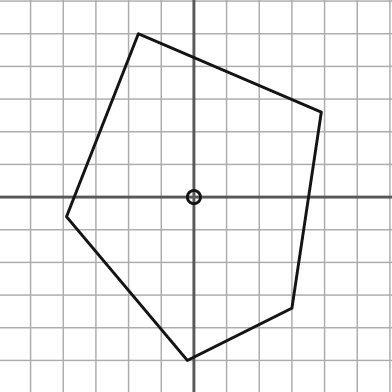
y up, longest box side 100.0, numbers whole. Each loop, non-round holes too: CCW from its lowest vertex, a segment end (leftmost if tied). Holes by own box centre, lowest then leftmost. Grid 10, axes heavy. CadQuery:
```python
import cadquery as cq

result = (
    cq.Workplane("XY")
    .moveTo(-2.0, -50.0)
    .lineTo(30.0, -34.0)
    .lineTo(39.0, 26.0)
    .lineTo(-17.0, 50.0)
    .lineTo(-39.0, -6.0)
    .close()
    .moveTo(0.0, 0.0)
    .circle(2.0)
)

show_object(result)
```